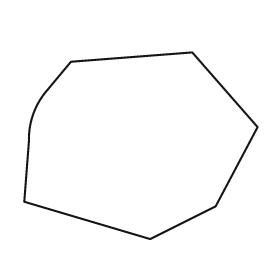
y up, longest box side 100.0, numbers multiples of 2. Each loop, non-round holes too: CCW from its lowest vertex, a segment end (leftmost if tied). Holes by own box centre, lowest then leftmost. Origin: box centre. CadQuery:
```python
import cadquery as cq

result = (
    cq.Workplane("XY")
    .moveTo(4.0, -40.0)
    .lineTo(32.0, -26.0)
    .lineTo(50.0, 8.0)
    .lineTo(22.0, 40.0)
    .lineTo(-30.0, 36.0)
    .lineTo(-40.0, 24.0)
    .threePointArc((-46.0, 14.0), (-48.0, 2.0))
    .lineTo(-50.0, -24.0)
    .close()
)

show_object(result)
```